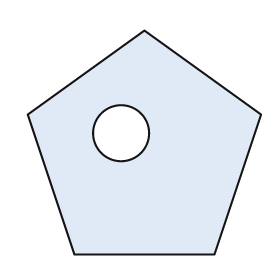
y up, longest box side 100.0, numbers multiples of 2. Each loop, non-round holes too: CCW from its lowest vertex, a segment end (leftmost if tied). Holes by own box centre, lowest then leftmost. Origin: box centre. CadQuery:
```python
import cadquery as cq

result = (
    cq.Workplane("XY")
    .moveTo(-30.0, -48.0)
    .lineTo(30.0, -48.0)
    .lineTo(50.0, 12.0)
    .lineTo(0.0, 48.0)
    .lineTo(-50.0, 12.0)
    .close()
    .moveTo(-10.0, 4.0)
    .circle(12.0)
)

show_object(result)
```